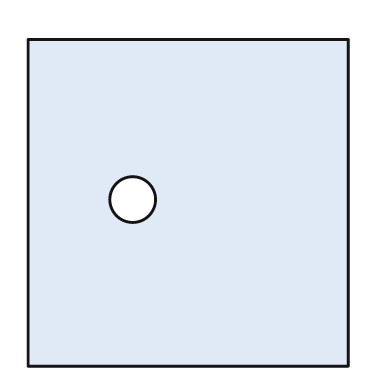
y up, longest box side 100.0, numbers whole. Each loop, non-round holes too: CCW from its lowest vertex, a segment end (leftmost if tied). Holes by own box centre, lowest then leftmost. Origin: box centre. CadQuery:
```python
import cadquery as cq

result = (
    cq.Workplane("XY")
    .moveTo(-49.0, -50.0)
    .lineTo(49.0, -50.0)
    .lineTo(49.0, 50.0)
    .lineTo(-49.0, 50.0)
    .close()
    .moveTo(-17.0, 1.0)
    .circle(7.0)
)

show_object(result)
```